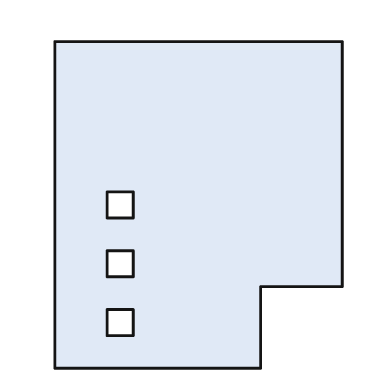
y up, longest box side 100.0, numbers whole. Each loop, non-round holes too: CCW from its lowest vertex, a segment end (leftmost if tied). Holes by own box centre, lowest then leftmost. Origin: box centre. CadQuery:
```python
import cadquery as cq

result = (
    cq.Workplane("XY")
    .moveTo(-44.0, -50.0)
    .lineTo(19.0, -50.0)
    .lineTo(19.0, -25.0)
    .lineTo(44.0, -25.0)
    .lineTo(44.0, 50.0)
    .lineTo(-44.0, 50.0)
    .close()
    .moveTo(-28.0, -40.0)
    .lineTo(-20.0, -40.0)
    .lineTo(-20.0, -32.0)
    .lineTo(-28.0, -32.0)
    .close()
    .moveTo(-28.0, -22.0)
    .lineTo(-20.0, -22.0)
    .lineTo(-20.0, -14.0)
    .lineTo(-28.0, -14.0)
    .close()
    .moveTo(-28.0, -4.0)
    .lineTo(-20.0, -4.0)
    .lineTo(-20.0, 4.0)
    .lineTo(-28.0, 4.0)
    .close()
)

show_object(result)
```